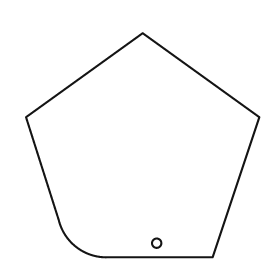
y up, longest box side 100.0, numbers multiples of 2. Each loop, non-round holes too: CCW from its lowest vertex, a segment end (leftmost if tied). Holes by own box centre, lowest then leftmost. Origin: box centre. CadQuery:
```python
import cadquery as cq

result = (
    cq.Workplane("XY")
    .moveTo(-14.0, -48.0)
    .lineTo(30.0, -48.0)
    .lineTo(50.0, 12.0)
    .lineTo(0.0, 48.0)
    .lineTo(-50.0, 12.0)
    .lineTo(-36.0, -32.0)
    .threePointArc((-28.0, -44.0), (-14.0, -48.0))
    .close()
    .moveTo(6.0, -42.0)
    .circle(2.0)
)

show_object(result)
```